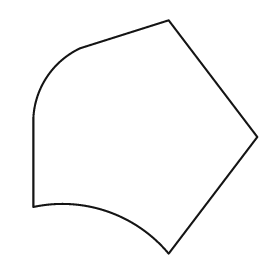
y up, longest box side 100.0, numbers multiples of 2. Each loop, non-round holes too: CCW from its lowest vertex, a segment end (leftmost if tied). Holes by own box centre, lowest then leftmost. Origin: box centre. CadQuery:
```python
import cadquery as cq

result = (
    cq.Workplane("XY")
    .moveTo(10.0, -50.0)
    .lineTo(48.0, 0.0)
    .lineTo(10.0, 50.0)
    .lineTo(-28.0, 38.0)
    .threePointArc((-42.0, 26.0), (-48.0, 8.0))
    .lineTo(-48.0, -30.0)
    .threePointArc((-16.0, -32.0), (10.0, -50.0))
    .close()
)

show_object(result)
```